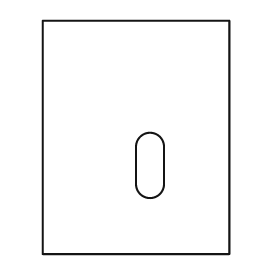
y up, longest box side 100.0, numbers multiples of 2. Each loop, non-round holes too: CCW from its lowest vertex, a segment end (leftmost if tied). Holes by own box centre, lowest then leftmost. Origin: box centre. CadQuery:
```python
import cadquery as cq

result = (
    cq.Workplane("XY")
    .moveTo(-40.0, -50.0)
    .lineTo(40.0, -50.0)
    .lineTo(40.0, 50.0)
    .lineTo(-40.0, 50.0)
    .close()
    .moveTo(0.0, -20.0)
    .threePointArc((6.0, -26.0), (12.0, -20.0))
    .lineTo(12.0, -4.0)
    .threePointArc((6.0, 2.0), (0.0, -4.0))
    .close()
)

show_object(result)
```